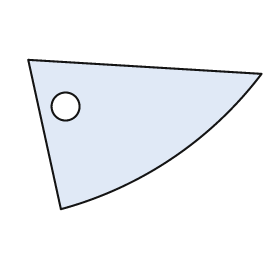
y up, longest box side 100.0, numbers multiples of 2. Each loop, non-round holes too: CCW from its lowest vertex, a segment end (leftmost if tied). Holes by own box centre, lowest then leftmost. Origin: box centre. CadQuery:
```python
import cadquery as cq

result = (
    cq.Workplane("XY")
    .moveTo(-36.0, -32.0)
    .threePointArc((12.0, -10.0), (50.0, 26.0))
    .lineTo(-50.0, 32.0)
    .close()
    .moveTo(-34.0, 12.0)
    .circle(6.0)
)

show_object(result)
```